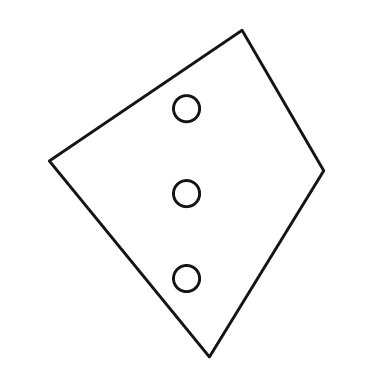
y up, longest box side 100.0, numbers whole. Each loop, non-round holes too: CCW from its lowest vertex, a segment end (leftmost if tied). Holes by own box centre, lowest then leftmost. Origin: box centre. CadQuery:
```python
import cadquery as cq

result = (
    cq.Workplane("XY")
    .moveTo(7.0, -50.0)
    .lineTo(42.0, 7.0)
    .lineTo(17.0, 50.0)
    .lineTo(-42.0, 10.0)
    .close()
    .moveTo(0.0, -26.0)
    .circle(4.0)
    .moveTo(0.0, 0.0)
    .circle(4.0)
    .moveTo(0.0, 26.0)
    .circle(4.0)
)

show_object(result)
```